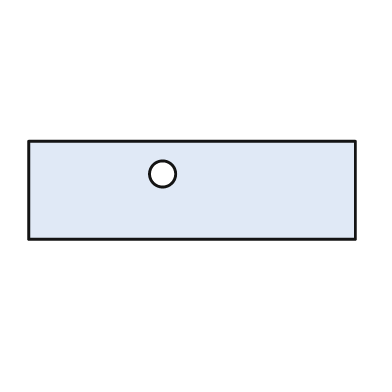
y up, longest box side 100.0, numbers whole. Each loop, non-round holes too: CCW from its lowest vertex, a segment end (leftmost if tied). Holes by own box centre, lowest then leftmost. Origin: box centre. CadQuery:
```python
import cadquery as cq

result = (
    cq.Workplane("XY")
    .moveTo(-50.0, -15.0)
    .lineTo(50.0, -15.0)
    .lineTo(50.0, 15.0)
    .lineTo(-50.0, 15.0)
    .close()
    .moveTo(-9.0, 5.0)
    .circle(4.0)
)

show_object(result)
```